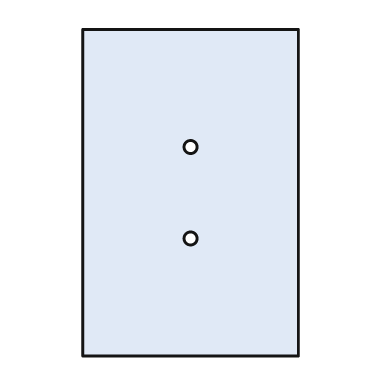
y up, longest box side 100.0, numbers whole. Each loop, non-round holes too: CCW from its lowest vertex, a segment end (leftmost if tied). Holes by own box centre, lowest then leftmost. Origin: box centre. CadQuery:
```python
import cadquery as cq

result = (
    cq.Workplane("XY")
    .moveTo(-33.0, -50.0)
    .lineTo(33.0, -50.0)
    .lineTo(33.0, 50.0)
    .lineTo(-33.0, 50.0)
    .close()
    .moveTo(0.0, -14.0)
    .circle(2.0)
    .moveTo(0.0, 14.0)
    .circle(2.0)
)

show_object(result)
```